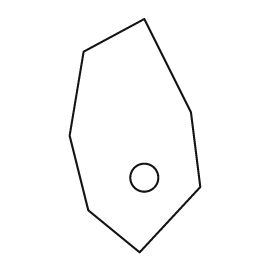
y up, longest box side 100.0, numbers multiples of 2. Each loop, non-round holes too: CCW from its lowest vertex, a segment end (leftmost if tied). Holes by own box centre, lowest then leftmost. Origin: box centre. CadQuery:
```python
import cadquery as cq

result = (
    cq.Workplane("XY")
    .moveTo(2.0, -50.0)
    .lineTo(28.0, -22.0)
    .lineTo(24.0, 10.0)
    .lineTo(4.0, 50.0)
    .lineTo(-22.0, 36.0)
    .lineTo(-28.0, 0.0)
    .lineTo(-20.0, -32.0)
    .close()
    .moveTo(4.0, -18.0)
    .circle(6.0)
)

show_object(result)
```